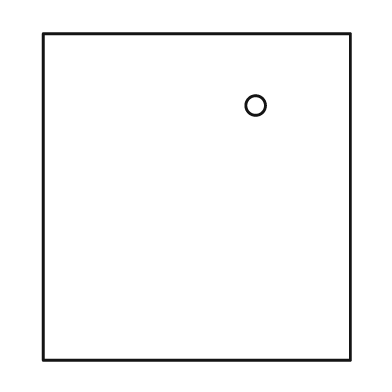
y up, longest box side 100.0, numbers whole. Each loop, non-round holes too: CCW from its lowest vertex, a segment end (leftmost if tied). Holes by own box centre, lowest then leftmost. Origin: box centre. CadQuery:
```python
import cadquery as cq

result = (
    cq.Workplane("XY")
    .moveTo(-47.0, -50.0)
    .lineTo(47.0, -50.0)
    .lineTo(47.0, 50.0)
    .lineTo(-47.0, 50.0)
    .close()
    .moveTo(18.0, 28.0)
    .circle(3.0)
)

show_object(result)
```